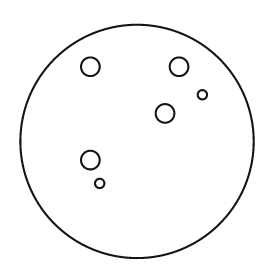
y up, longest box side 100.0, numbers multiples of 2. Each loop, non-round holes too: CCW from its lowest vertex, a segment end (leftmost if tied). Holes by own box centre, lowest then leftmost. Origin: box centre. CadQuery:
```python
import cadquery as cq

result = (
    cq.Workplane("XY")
    .moveTo(0.0, 0.0)
    .circle(50.0)
    .moveTo(-16.0, -18.0)
    .circle(2.0)
    .moveTo(-20.0, -8.0)
    .circle(4.0)
    .moveTo(12.0, 12.0)
    .circle(4.0)
    .moveTo(28.0, 20.0)
    .circle(2.0)
    .moveTo(-20.0, 32.0)
    .circle(4.0)
    .moveTo(18.0, 32.0)
    .circle(4.0)
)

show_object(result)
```